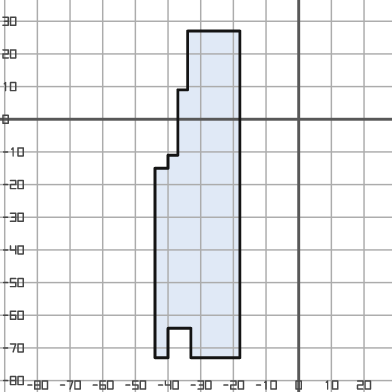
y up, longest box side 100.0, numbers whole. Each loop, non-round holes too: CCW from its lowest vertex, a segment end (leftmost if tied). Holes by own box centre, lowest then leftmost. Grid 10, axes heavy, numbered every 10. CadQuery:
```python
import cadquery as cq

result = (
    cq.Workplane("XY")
    .moveTo(-44.0, -73.0)
    .lineTo(-40.0, -73.0)
    .lineTo(-40.0, -64.0)
    .lineTo(-33.0, -64.0)
    .lineTo(-33.0, -73.0)
    .lineTo(-18.0, -73.0)
    .lineTo(-18.0, 27.0)
    .lineTo(-34.0, 27.0)
    .lineTo(-34.0, 9.0)
    .lineTo(-37.0, 9.0)
    .lineTo(-37.0, -11.0)
    .lineTo(-40.0, -11.0)
    .lineTo(-40.0, -15.0)
    .lineTo(-44.0, -15.0)
    .close()
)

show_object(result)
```